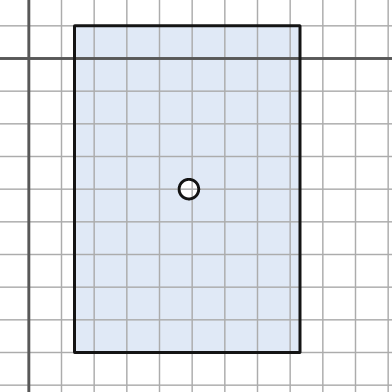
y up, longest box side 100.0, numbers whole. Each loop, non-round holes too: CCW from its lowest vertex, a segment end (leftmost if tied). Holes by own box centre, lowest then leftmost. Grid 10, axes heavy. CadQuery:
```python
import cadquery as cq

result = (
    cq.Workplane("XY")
    .moveTo(14.0, -90.0)
    .lineTo(83.0, -90.0)
    .lineTo(83.0, 10.0)
    .lineTo(14.0, 10.0)
    .close()
    .moveTo(49.0, -40.0)
    .circle(3.0)
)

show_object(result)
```